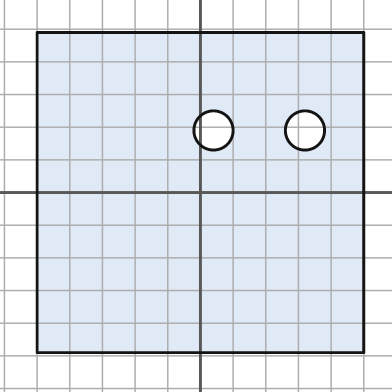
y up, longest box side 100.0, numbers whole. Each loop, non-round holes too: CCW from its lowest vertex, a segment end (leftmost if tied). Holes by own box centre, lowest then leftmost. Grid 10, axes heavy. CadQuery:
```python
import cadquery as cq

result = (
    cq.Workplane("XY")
    .moveTo(-50.0, -49.0)
    .lineTo(50.0, -49.0)
    .lineTo(50.0, 49.0)
    .lineTo(-50.0, 49.0)
    .close()
    .moveTo(4.0, 19.0)
    .circle(6.0)
    .moveTo(32.0, 19.0)
    .circle(6.0)
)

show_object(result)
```